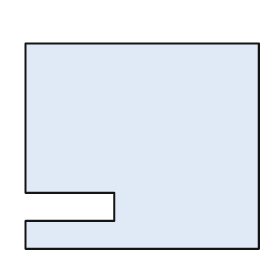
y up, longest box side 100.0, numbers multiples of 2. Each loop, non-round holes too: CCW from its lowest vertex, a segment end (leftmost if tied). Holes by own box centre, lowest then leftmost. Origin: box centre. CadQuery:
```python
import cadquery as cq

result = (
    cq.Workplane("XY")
    .moveTo(-50.0, -44.0)
    .lineTo(50.0, -44.0)
    .lineTo(50.0, 44.0)
    .lineTo(-50.0, 44.0)
    .lineTo(-50.0, -20.0)
    .lineTo(-12.0, -20.0)
    .lineTo(-12.0, -32.0)
    .lineTo(-50.0, -32.0)
    .close()
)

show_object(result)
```